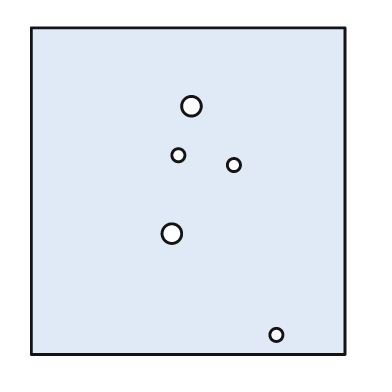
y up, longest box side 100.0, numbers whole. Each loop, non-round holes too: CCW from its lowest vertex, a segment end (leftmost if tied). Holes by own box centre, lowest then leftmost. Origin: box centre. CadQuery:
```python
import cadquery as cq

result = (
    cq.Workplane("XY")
    .moveTo(-48.0, -50.0)
    .lineTo(48.0, -50.0)
    .lineTo(48.0, 50.0)
    .lineTo(-48.0, 50.0)
    .close()
    .moveTo(27.0, -44.0)
    .circle(2.0)
    .moveTo(-5.0, -13.0)
    .circle(3.0)
    .moveTo(14.0, 8.0)
    .circle(2.0)
    .moveTo(-3.0, 11.0)
    .circle(2.0)
    .moveTo(1.0, 26.0)
    .circle(3.0)
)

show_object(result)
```